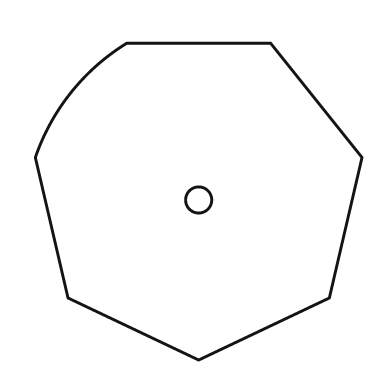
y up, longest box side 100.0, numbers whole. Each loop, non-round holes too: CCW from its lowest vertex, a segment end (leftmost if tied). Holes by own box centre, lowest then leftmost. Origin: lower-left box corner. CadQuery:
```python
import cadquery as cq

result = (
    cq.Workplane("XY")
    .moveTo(50.0, 0.0)
    .lineTo(90.0, 19.0)
    .lineTo(100.0, 62.0)
    .lineTo(72.0, 97.0)
    .lineTo(28.0, 97.0)
    .threePointArc((11.0, 82.0), (0.0, 62.0))
    .lineTo(10.0, 19.0)
    .close()
    .moveTo(50.0, 49.0)
    .circle(4.0)
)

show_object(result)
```